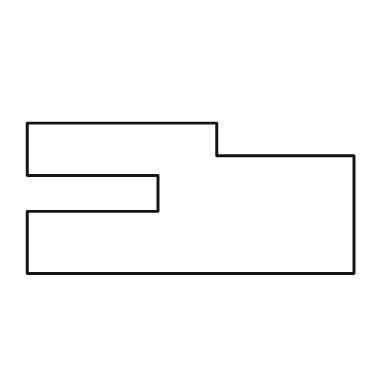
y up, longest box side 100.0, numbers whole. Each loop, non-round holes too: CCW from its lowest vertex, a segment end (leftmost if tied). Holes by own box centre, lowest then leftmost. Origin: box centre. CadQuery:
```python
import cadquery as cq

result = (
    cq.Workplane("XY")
    .moveTo(-50.0, -23.0)
    .lineTo(50.0, -23.0)
    .lineTo(50.0, 13.0)
    .lineTo(8.0, 13.0)
    .lineTo(8.0, 23.0)
    .lineTo(-50.0, 23.0)
    .lineTo(-50.0, 7.0)
    .lineTo(-10.0, 7.0)
    .lineTo(-10.0, -4.0)
    .lineTo(-50.0, -4.0)
    .close()
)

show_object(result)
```